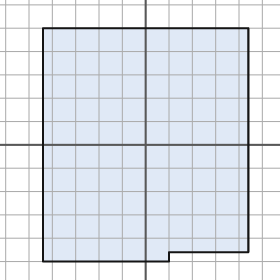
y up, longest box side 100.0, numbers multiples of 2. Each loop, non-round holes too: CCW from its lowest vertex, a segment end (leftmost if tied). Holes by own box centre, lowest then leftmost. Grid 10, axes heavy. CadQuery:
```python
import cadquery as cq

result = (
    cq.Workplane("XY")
    .moveTo(-44.0, -50.0)
    .lineTo(10.0, -50.0)
    .lineTo(10.0, -46.0)
    .lineTo(44.0, -46.0)
    .lineTo(44.0, 50.0)
    .lineTo(-44.0, 50.0)
    .close()
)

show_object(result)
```